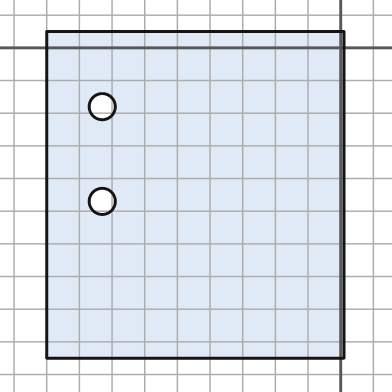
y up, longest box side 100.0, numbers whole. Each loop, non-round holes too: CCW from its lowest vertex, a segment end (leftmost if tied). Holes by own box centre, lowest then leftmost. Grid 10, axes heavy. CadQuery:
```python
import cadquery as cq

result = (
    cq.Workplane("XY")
    .moveTo(-90.0, -95.0)
    .lineTo(1.0, -95.0)
    .lineTo(1.0, 5.0)
    .lineTo(-90.0, 5.0)
    .close()
    .moveTo(-73.0, -47.0)
    .circle(4.0)
    .moveTo(-73.0, -18.0)
    .circle(4.0)
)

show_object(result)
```